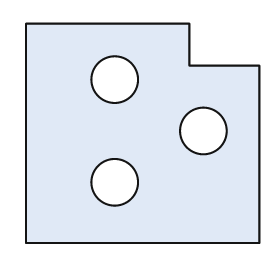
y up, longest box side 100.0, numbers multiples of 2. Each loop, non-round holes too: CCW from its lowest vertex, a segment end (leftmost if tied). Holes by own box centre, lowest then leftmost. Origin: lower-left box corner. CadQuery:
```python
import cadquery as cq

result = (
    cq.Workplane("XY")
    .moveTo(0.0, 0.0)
    .lineTo(100.0, 0.0)
    .lineTo(100.0, 76.0)
    .lineTo(70.0, 76.0)
    .lineTo(70.0, 94.0)
    .lineTo(0.0, 94.0)
    .close()
    .moveTo(38.0, 26.0)
    .circle(10.0)
    .moveTo(76.0, 48.0)
    .circle(10.0)
    .moveTo(38.0, 70.0)
    .circle(10.0)
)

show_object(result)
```